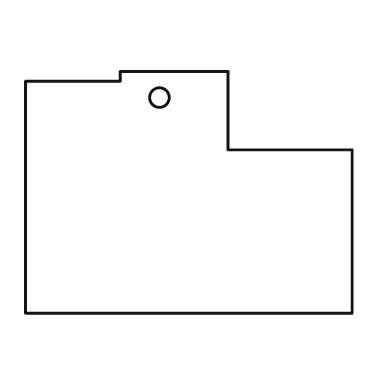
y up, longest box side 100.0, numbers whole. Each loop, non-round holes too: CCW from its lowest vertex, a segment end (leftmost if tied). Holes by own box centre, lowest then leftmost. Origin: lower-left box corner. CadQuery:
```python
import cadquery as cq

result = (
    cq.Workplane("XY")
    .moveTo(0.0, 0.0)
    .lineTo(100.0, 0.0)
    .lineTo(100.0, 50.0)
    .lineTo(62.0, 50.0)
    .lineTo(62.0, 74.0)
    .lineTo(29.0, 74.0)
    .lineTo(29.0, 71.0)
    .lineTo(0.0, 71.0)
    .close()
    .moveTo(41.0, 66.0)
    .circle(3.0)
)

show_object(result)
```